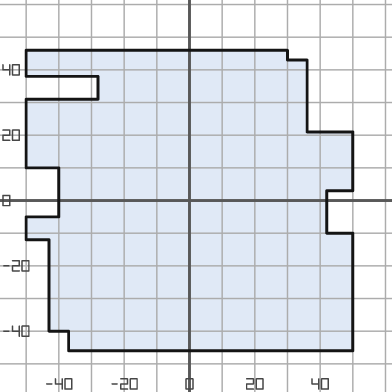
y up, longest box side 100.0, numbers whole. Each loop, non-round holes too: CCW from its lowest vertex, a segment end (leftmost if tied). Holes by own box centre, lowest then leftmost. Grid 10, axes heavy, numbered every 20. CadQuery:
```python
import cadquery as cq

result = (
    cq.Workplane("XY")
    .moveTo(-37.0, -46.0)
    .lineTo(50.0, -46.0)
    .lineTo(50.0, -10.0)
    .lineTo(42.0, -10.0)
    .lineTo(42.0, 3.0)
    .lineTo(50.0, 3.0)
    .lineTo(50.0, 21.0)
    .lineTo(36.0, 21.0)
    .lineTo(36.0, 43.0)
    .lineTo(30.0, 43.0)
    .lineTo(30.0, 46.0)
    .lineTo(-50.0, 46.0)
    .lineTo(-50.0, 38.0)
    .lineTo(-28.0, 38.0)
    .lineTo(-28.0, 31.0)
    .lineTo(-50.0, 31.0)
    .lineTo(-50.0, 10.0)
    .lineTo(-40.0, 10.0)
    .lineTo(-40.0, -5.0)
    .lineTo(-50.0, -5.0)
    .lineTo(-50.0, -12.0)
    .lineTo(-43.0, -12.0)
    .lineTo(-43.0, -40.0)
    .lineTo(-37.0, -40.0)
    .close()
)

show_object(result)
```